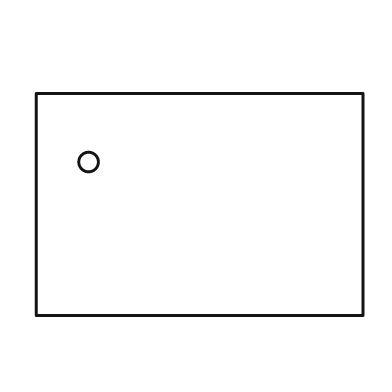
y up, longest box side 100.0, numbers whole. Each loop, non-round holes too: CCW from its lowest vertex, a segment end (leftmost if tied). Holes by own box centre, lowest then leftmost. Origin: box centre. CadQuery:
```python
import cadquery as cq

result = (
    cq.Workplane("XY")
    .moveTo(-50.0, -34.0)
    .lineTo(50.0, -34.0)
    .lineTo(50.0, 34.0)
    .lineTo(-50.0, 34.0)
    .close()
    .moveTo(-34.0, 13.0)
    .circle(3.0)
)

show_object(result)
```